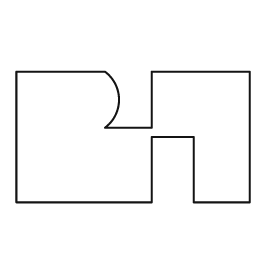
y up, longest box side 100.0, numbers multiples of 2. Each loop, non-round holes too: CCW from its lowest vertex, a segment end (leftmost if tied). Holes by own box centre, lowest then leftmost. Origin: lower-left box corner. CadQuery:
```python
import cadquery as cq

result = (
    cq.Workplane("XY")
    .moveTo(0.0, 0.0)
    .lineTo(58.0, 0.0)
    .lineTo(58.0, 28.0)
    .lineTo(76.0, 28.0)
    .lineTo(76.0, 0.0)
    .lineTo(100.0, 0.0)
    .lineTo(100.0, 56.0)
    .lineTo(58.0, 56.0)
    .lineTo(58.0, 32.0)
    .lineTo(38.0, 32.0)
    .threePointArc((44.0, 44.0), (38.0, 56.0))
    .lineTo(0.0, 56.0)
    .close()
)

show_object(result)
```